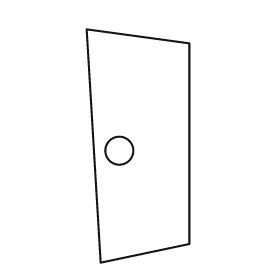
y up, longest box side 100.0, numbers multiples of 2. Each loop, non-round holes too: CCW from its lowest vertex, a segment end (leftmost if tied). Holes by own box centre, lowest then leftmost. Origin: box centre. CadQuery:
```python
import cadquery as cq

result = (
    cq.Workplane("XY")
    .moveTo(-16.0, -50.0)
    .lineTo(22.0, -42.0)
    .lineTo(22.0, 44.0)
    .lineTo(-22.0, 50.0)
    .close()
    .moveTo(-8.0, -2.0)
    .circle(6.0)
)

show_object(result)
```